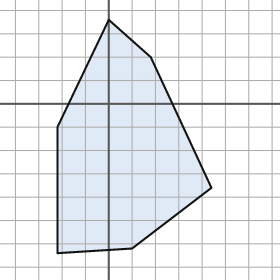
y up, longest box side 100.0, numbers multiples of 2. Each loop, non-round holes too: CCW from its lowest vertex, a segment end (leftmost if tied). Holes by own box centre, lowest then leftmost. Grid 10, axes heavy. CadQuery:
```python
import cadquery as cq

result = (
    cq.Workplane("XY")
    .moveTo(-22.0, -64.0)
    .lineTo(10.0, -62.0)
    .lineTo(44.0, -36.0)
    .lineTo(18.0, 20.0)
    .lineTo(0.0, 36.0)
    .lineTo(-22.0, -10.0)
    .close()
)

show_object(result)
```